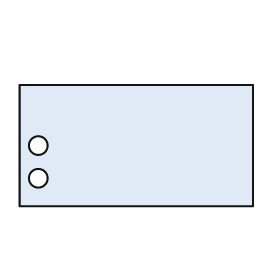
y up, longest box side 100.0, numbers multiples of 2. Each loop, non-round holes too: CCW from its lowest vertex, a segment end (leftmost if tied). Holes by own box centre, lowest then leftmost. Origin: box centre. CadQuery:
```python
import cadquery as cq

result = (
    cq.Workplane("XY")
    .moveTo(-50.0, -26.0)
    .lineTo(50.0, -26.0)
    .lineTo(50.0, 26.0)
    .lineTo(-50.0, 26.0)
    .close()
    .moveTo(-42.0, -14.0)
    .circle(4.0)
    .moveTo(-42.0, 0.0)
    .circle(4.0)
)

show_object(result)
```